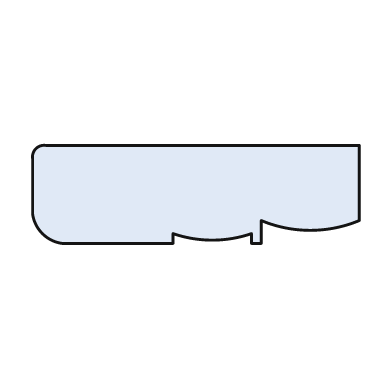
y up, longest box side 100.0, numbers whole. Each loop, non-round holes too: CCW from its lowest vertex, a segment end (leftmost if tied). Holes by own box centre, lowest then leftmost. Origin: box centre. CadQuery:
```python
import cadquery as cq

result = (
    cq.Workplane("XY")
    .moveTo(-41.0, -15.0)
    .lineTo(-7.0, -15.0)
    .lineTo(-7.0, -12.0)
    .threePointArc((5.0, -14.0), (17.0, -12.0))
    .lineTo(17.0, -15.0)
    .lineTo(20.0, -15.0)
    .lineTo(20.0, -8.0)
    .threePointArc((35.0, -11.0), (50.0, -8.0))
    .lineTo(50.0, 15.0)
    .lineTo(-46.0, 15.0)
    .threePointArc((-49.0, 14.0), (-50.0, 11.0))
    .lineTo(-50.0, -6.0)
    .threePointArc((-47.0, -12.0), (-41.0, -15.0))
    .close()
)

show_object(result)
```